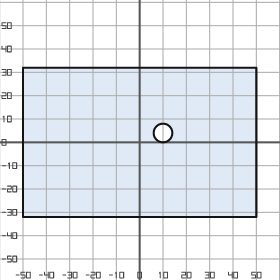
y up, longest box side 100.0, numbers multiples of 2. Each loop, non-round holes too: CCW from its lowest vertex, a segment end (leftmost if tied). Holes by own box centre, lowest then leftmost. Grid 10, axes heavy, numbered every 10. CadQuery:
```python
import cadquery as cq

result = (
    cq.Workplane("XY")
    .moveTo(-50.0, -32.0)
    .lineTo(50.0, -32.0)
    .lineTo(50.0, 32.0)
    .lineTo(-50.0, 32.0)
    .close()
    .moveTo(10.0, 4.0)
    .circle(4.0)
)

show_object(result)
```